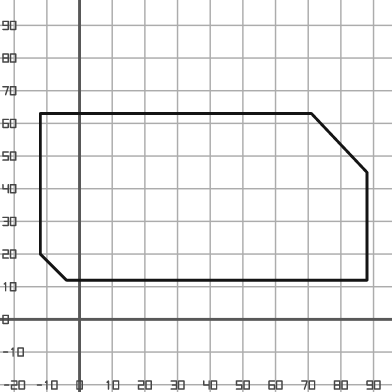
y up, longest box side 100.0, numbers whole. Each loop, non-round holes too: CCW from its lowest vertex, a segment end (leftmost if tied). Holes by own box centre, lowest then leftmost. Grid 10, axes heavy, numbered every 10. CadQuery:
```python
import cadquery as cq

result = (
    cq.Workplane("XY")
    .moveTo(-4.0, 12.0)
    .lineTo(88.0, 12.0)
    .lineTo(88.0, 45.0)
    .lineTo(71.0, 63.0)
    .lineTo(-12.0, 63.0)
    .lineTo(-12.0, 20.0)
    .close()
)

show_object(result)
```